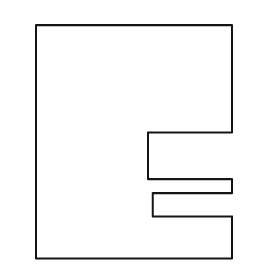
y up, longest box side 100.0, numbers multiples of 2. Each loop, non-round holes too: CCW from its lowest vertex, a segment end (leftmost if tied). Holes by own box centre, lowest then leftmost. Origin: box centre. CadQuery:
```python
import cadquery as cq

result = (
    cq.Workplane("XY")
    .moveTo(-42.0, -50.0)
    .lineTo(42.0, -50.0)
    .lineTo(42.0, -32.0)
    .lineTo(8.0, -32.0)
    .lineTo(8.0, -22.0)
    .lineTo(42.0, -22.0)
    .lineTo(42.0, -16.0)
    .lineTo(6.0, -16.0)
    .lineTo(6.0, 4.0)
    .lineTo(42.0, 4.0)
    .lineTo(42.0, 50.0)
    .lineTo(-42.0, 50.0)
    .close()
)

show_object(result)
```